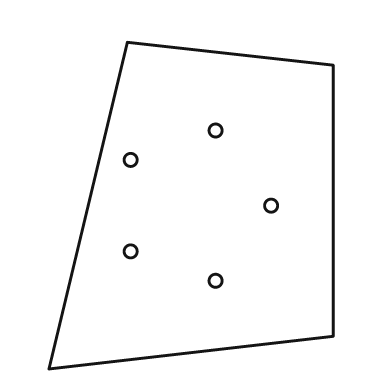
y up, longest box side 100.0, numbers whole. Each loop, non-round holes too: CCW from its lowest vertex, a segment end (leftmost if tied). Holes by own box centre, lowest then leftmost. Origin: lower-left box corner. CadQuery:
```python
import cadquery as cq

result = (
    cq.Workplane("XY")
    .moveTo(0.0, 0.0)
    .lineTo(87.0, 10.0)
    .lineTo(87.0, 93.0)
    .lineTo(24.0, 100.0)
    .close()
    .moveTo(51.0, 27.0)
    .circle(2.0)
    .moveTo(25.0, 36.0)
    .circle(2.0)
    .moveTo(68.0, 50.0)
    .circle(2.0)
    .moveTo(25.0, 64.0)
    .circle(2.0)
    .moveTo(51.0, 73.0)
    .circle(2.0)
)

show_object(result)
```